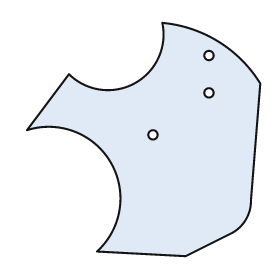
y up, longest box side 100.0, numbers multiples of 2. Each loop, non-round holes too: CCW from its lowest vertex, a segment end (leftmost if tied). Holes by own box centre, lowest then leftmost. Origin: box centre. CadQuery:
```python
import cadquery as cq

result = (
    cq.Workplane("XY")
    .moveTo(18.0, -50.0)
    .lineTo(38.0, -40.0)
    .threePointArc((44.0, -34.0), (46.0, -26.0))
    .lineTo(50.0, 24.0)
    .threePointArc((32.0, 42.0), (8.0, 50.0))
    .threePointArc((-4.0, 24.0), (-32.0, 28.0))
    .lineTo(-50.0, 4.0)
    .threePointArc((-14.0, -10.0), (-20.0, -48.0))
    .close()
    .moveTo(4.0, 2.0)
    .circle(2.0)
    .moveTo(28.0, 20.0)
    .circle(2.0)
    .moveTo(28.0, 36.0)
    .circle(2.0)
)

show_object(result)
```